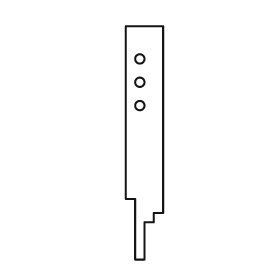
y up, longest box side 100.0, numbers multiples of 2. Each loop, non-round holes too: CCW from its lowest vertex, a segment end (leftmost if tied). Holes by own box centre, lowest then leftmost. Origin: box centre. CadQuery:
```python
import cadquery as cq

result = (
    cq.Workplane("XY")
    .moveTo(-4.0, -50.0)
    .lineTo(0.0, -50.0)
    .lineTo(0.0, -34.0)
    .lineTo(4.0, -34.0)
    .lineTo(4.0, -30.0)
    .lineTo(8.0, -30.0)
    .lineTo(8.0, 50.0)
    .lineTo(-8.0, 50.0)
    .lineTo(-8.0, -24.0)
    .lineTo(-4.0, -24.0)
    .close()
    .moveTo(-2.0, 16.0)
    .circle(2.0)
    .moveTo(-2.0, 26.0)
    .circle(2.0)
    .moveTo(-2.0, 36.0)
    .circle(2.0)
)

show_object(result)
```